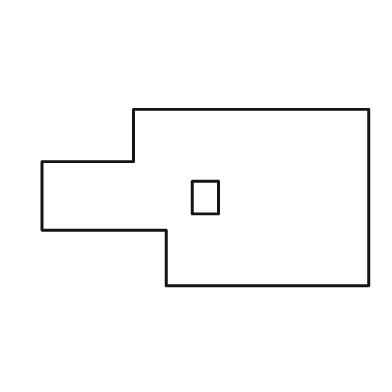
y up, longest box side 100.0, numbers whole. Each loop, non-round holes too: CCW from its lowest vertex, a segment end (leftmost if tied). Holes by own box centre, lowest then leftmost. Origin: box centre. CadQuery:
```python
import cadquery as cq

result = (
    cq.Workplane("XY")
    .moveTo(-12.0, -27.0)
    .lineTo(50.0, -27.0)
    .lineTo(50.0, 27.0)
    .lineTo(-22.0, 27.0)
    .lineTo(-22.0, 11.0)
    .lineTo(-50.0, 11.0)
    .lineTo(-50.0, -10.0)
    .lineTo(-12.0, -10.0)
    .close()
    .moveTo(-4.0, -5.0)
    .lineTo(4.0, -5.0)
    .lineTo(4.0, 5.0)
    .lineTo(-4.0, 5.0)
    .close()
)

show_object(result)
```